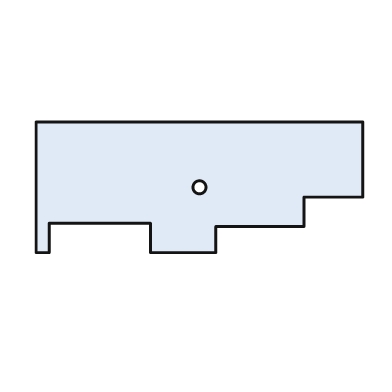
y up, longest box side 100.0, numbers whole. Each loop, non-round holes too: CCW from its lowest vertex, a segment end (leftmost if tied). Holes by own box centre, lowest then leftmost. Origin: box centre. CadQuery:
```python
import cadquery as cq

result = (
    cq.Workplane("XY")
    .moveTo(-50.0, -20.0)
    .lineTo(-46.0, -20.0)
    .lineTo(-46.0, -11.0)
    .lineTo(-15.0, -11.0)
    .lineTo(-15.0, -20.0)
    .lineTo(5.0, -20.0)
    .lineTo(5.0, -12.0)
    .lineTo(32.0, -12.0)
    .lineTo(32.0, -3.0)
    .lineTo(50.0, -3.0)
    .lineTo(50.0, 20.0)
    .lineTo(-50.0, 20.0)
    .close()
    .moveTo(0.0, 0.0)
    .circle(2.0)
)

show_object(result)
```